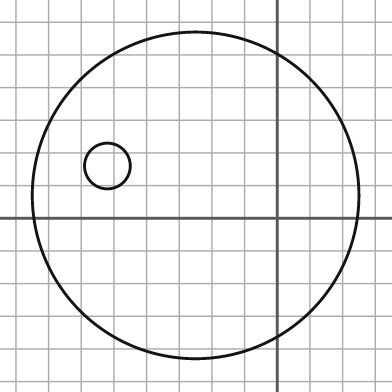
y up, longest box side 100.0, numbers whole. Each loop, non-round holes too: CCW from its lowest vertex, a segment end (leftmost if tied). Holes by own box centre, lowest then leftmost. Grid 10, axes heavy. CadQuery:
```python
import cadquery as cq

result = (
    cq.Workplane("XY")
    .moveTo(-25.0, 7.0)
    .circle(50.0)
    .moveTo(-52.0, 16.0)
    .circle(7.0)
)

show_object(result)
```